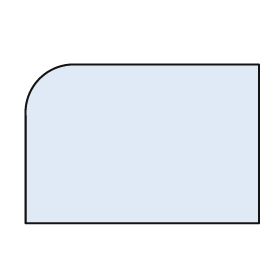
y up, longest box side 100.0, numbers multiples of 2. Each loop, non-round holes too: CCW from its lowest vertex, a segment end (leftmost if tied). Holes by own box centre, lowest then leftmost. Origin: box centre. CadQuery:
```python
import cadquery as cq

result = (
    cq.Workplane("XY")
    .moveTo(-50.0, -34.0)
    .lineTo(50.0, -34.0)
    .lineTo(50.0, 34.0)
    .lineTo(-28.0, 34.0)
    .threePointArc((-44.0, 28.0), (-50.0, 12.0))
    .close()
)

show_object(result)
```